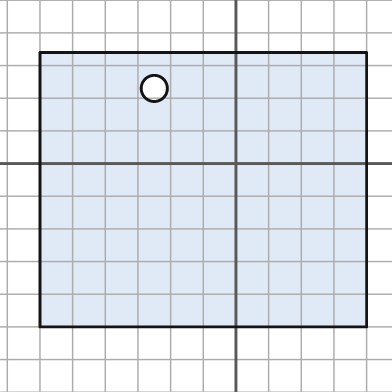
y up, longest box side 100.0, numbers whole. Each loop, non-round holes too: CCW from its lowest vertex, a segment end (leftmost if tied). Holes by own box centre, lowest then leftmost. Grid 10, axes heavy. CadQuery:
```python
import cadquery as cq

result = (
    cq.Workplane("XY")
    .moveTo(-60.0, -50.0)
    .lineTo(40.0, -50.0)
    .lineTo(40.0, 34.0)
    .lineTo(-60.0, 34.0)
    .close()
    .moveTo(-25.0, 23.0)
    .circle(4.0)
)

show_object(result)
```